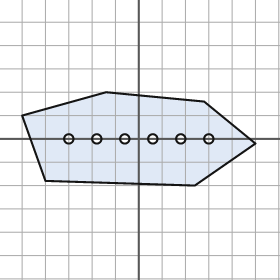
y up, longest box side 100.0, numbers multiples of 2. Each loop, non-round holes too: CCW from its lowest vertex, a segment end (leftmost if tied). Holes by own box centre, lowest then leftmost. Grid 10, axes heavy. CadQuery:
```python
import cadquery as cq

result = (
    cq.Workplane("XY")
    .moveTo(24.0, -20.0)
    .lineTo(50.0, -2.0)
    .lineTo(28.0, 16.0)
    .lineTo(-14.0, 20.0)
    .lineTo(-50.0, 10.0)
    .lineTo(-40.0, -18.0)
    .close()
    .moveTo(-30.0, 0.0)
    .circle(2.0)
    .moveTo(-18.0, 0.0)
    .circle(2.0)
    .moveTo(-6.0, 0.0)
    .circle(2.0)
    .moveTo(6.0, 0.0)
    .circle(2.0)
    .moveTo(18.0, 0.0)
    .circle(2.0)
    .moveTo(30.0, 0.0)
    .circle(2.0)
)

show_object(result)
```